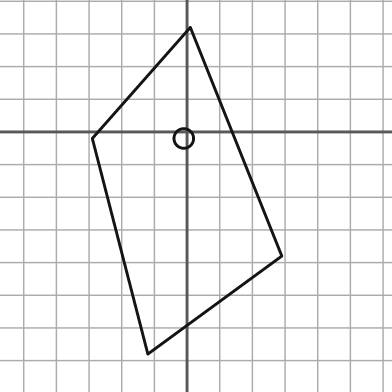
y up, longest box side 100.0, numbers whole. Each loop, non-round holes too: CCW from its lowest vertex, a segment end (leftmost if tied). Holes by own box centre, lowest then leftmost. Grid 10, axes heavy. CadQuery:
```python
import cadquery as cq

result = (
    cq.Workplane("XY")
    .moveTo(-12.0, -68.0)
    .lineTo(29.0, -38.0)
    .lineTo(1.0, 32.0)
    .lineTo(-29.0, -2.0)
    .close()
    .moveTo(-1.0, -2.0)
    .circle(3.0)
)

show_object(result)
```